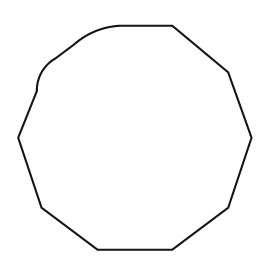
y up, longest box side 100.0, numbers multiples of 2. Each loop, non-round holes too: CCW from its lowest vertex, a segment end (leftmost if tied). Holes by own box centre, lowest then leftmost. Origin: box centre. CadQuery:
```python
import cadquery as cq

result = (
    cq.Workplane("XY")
    .moveTo(-16.0, -48.0)
    .lineTo(16.0, -48.0)
    .lineTo(40.0, -30.0)
    .lineTo(50.0, 0.0)
    .lineTo(40.0, 28.0)
    .lineTo(16.0, 48.0)
    .lineTo(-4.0, 48.0)
    .threePointArc((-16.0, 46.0), (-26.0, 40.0))
    .lineTo(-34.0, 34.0)
    .threePointArc((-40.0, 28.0), (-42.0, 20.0))
    .lineTo(-50.0, 0.0)
    .lineTo(-40.0, -30.0)
    .close()
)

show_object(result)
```